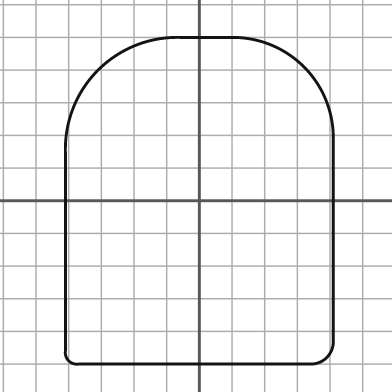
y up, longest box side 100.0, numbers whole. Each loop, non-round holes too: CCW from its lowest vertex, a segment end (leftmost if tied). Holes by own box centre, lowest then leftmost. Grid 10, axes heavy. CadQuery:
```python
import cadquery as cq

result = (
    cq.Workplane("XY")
    .moveTo(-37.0, -50.0)
    .lineTo(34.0, -50.0)
    .threePointArc((39.0, -48.0), (41.0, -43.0))
    .lineTo(41.0, 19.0)
    .threePointArc((32.0, 41.0), (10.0, 50.0))
    .lineTo(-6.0, 50.0)
    .threePointArc((-31.0, 40.0), (-41.0, 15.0))
    .lineTo(-41.0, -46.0)
    .threePointArc((-40.0, -49.0), (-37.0, -50.0))
    .close()
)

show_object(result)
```